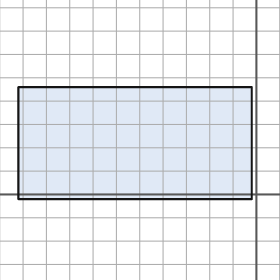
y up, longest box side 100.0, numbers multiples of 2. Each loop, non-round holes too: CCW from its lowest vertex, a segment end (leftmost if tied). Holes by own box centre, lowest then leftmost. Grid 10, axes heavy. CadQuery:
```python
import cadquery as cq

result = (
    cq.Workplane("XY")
    .moveTo(-102.0, -2.0)
    .lineTo(-2.0, -2.0)
    .lineTo(-2.0, 46.0)
    .lineTo(-102.0, 46.0)
    .close()
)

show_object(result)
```